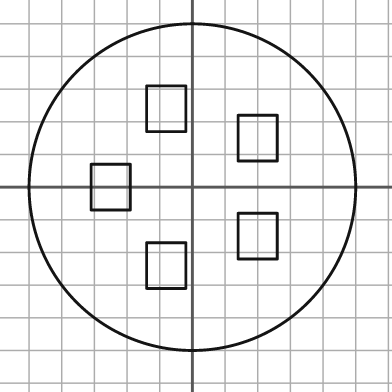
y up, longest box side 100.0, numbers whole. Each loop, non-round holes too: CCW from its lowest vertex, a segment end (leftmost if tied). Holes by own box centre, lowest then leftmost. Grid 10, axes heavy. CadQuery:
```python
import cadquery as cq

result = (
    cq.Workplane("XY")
    .moveTo(0.0, 0.0)
    .circle(50.0)
    .moveTo(-14.0, -31.0)
    .lineTo(-2.0, -31.0)
    .lineTo(-2.0, -17.0)
    .lineTo(-14.0, -17.0)
    .close()
    .moveTo(14.0, -22.0)
    .lineTo(26.0, -22.0)
    .lineTo(26.0, -8.0)
    .lineTo(14.0, -8.0)
    .close()
    .moveTo(-31.0, -7.0)
    .lineTo(-19.0, -7.0)
    .lineTo(-19.0, 7.0)
    .lineTo(-31.0, 7.0)
    .close()
    .moveTo(14.0, 8.0)
    .lineTo(26.0, 8.0)
    .lineTo(26.0, 22.0)
    .lineTo(14.0, 22.0)
    .close()
    .moveTo(-14.0, 17.0)
    .lineTo(-2.0, 17.0)
    .lineTo(-2.0, 31.0)
    .lineTo(-14.0, 31.0)
    .close()
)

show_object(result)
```